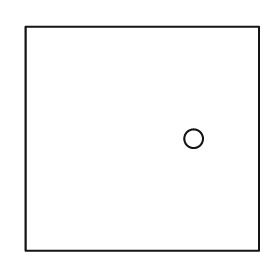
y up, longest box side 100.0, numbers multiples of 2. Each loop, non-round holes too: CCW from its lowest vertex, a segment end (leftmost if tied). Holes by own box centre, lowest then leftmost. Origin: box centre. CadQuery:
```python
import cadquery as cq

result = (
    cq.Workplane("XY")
    .moveTo(-50.0, -48.0)
    .lineTo(50.0, -48.0)
    .lineTo(50.0, 48.0)
    .lineTo(-50.0, 48.0)
    .close()
    .moveTo(22.0, 0.0)
    .circle(4.0)
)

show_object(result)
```